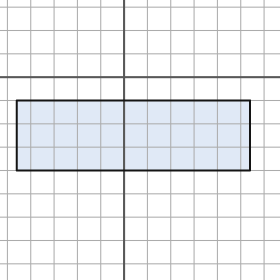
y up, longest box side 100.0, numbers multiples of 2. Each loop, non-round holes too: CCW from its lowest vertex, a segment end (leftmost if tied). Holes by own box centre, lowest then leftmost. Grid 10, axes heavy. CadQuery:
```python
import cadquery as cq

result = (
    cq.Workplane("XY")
    .moveTo(-46.0, -40.0)
    .lineTo(54.0, -40.0)
    .lineTo(54.0, -10.0)
    .lineTo(-46.0, -10.0)
    .close()
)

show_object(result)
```